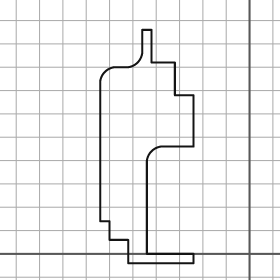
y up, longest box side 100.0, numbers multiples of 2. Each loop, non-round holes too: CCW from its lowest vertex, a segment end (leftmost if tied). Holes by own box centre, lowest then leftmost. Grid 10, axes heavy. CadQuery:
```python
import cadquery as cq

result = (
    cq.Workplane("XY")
    .moveTo(-52.0, -4.0)
    .lineTo(-24.0, -4.0)
    .lineTo(-24.0, 0.0)
    .lineTo(-44.0, 0.0)
    .lineTo(-44.0, 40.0)
    .threePointArc((-42.0, 44.0), (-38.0, 46.0))
    .lineTo(-24.0, 46.0)
    .lineTo(-24.0, 68.0)
    .lineTo(-32.0, 68.0)
    .lineTo(-32.0, 82.0)
    .lineTo(-42.0, 82.0)
    .lineTo(-42.0, 96.0)
    .lineTo(-46.0, 96.0)
    .lineTo(-46.0, 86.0)
    .threePointArc((-48.0, 82.0), (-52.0, 80.0))
    .lineTo(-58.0, 80.0)
    .threePointArc((-62.0, 78.0), (-64.0, 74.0))
    .lineTo(-64.0, 14.0)
    .lineTo(-60.0, 14.0)
    .lineTo(-60.0, 6.0)
    .lineTo(-52.0, 6.0)
    .close()
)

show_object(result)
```